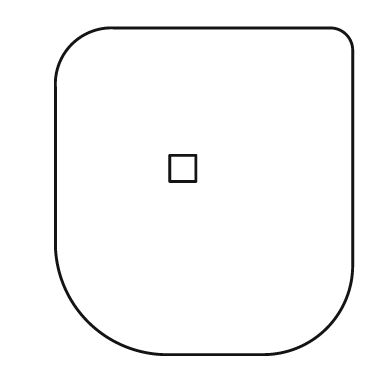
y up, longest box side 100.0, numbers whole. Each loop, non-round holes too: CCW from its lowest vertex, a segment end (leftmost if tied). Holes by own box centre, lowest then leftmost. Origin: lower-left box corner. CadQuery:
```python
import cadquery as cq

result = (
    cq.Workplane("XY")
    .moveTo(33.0, 0.0)
    .lineTo(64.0, 0.0)
    .threePointArc((83.0, 8.0), (91.0, 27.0))
    .lineTo(91.0, 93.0)
    .threePointArc((89.0, 98.0), (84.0, 100.0))
    .lineTo(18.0, 100.0)
    .threePointArc((5.0, 95.0), (0.0, 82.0))
    .lineTo(0.0, 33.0)
    .threePointArc((10.0, 10.0), (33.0, 0.0))
    .close()
    .moveTo(35.0, 53.0)
    .lineTo(43.0, 53.0)
    .lineTo(43.0, 61.0)
    .lineTo(35.0, 61.0)
    .close()
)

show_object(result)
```